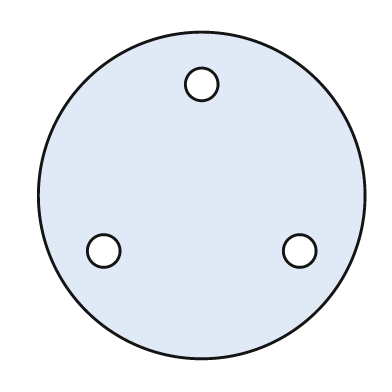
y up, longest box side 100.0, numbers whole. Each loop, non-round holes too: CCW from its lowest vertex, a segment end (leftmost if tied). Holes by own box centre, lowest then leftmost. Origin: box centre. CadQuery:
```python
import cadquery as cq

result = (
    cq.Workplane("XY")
    .moveTo(0.0, 0.0)
    .circle(50.0)
    .moveTo(-30.0, -17.0)
    .circle(5.0)
    .moveTo(30.0, -17.0)
    .circle(5.0)
    .moveTo(0.0, 34.0)
    .circle(5.0)
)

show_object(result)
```